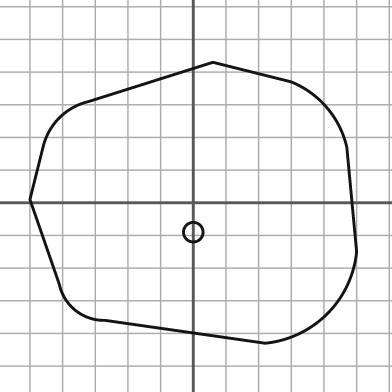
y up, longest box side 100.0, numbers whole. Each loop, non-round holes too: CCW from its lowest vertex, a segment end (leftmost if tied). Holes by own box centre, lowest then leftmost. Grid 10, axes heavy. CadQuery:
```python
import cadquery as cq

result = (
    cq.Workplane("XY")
    .moveTo(22.0, -43.0)
    .threePointArc((41.0, -34.0), (50.0, -15.0))
    .lineTo(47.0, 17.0)
    .threePointArc((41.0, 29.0), (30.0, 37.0))
    .lineTo(6.0, 43.0)
    .lineTo(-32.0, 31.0)
    .threePointArc((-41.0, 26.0), (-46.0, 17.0))
    .lineTo(-50.0, 1.0)
    .lineTo(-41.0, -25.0)
    .threePointArc((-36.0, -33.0), (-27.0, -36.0))
    .close()
    .moveTo(0.0, -9.0)
    .circle(3.0)
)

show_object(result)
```